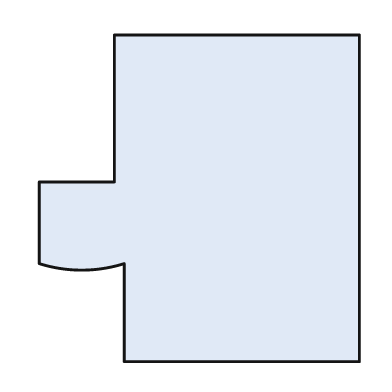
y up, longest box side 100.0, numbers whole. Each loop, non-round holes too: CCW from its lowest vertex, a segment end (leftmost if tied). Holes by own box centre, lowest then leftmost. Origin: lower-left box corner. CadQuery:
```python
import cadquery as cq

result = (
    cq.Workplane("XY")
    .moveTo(26.0, 0.0)
    .lineTo(98.0, 0.0)
    .lineTo(98.0, 100.0)
    .lineTo(23.0, 100.0)
    .lineTo(23.0, 55.0)
    .lineTo(0.0, 55.0)
    .lineTo(0.0, 30.0)
    .threePointArc((13.0, 28.0), (26.0, 30.0))
    .close()
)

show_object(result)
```